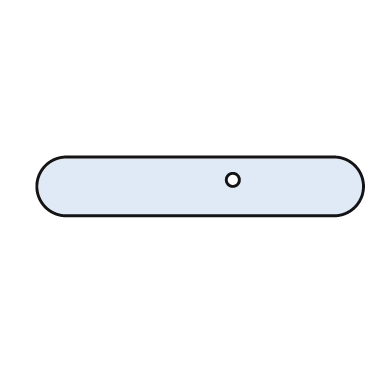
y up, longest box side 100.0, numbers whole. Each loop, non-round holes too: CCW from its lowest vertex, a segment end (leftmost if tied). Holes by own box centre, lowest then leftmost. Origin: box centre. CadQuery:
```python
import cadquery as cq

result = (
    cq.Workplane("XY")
    .moveTo(-41.0, -9.0)
    .lineTo(41.0, -9.0)
    .threePointArc((50.0, 0.0), (41.0, 9.0))
    .lineTo(-41.0, 9.0)
    .threePointArc((-50.0, 0.0), (-41.0, -9.0))
    .close()
    .moveTo(10.0, 2.0)
    .circle(2.0)
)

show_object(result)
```